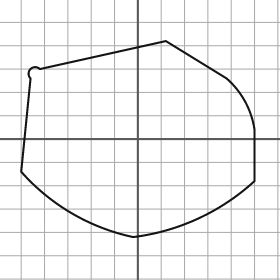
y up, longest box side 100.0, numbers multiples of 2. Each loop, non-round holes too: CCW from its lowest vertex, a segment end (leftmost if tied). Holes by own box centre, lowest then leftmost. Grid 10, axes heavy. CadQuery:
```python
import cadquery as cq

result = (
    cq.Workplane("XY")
    .moveTo(-2.0, -42.0)
    .threePointArc((26.0, -34.0), (50.0, -18.0))
    .lineTo(50.0, 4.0)
    .threePointArc((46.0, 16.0), (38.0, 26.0))
    .lineTo(12.0, 42.0)
    .lineTo(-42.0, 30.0)
    .threePointArc((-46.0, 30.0), (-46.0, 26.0))
    .lineTo(-50.0, -14.0)
    .threePointArc((-28.0, -32.0), (-2.0, -42.0))
    .close()
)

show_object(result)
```